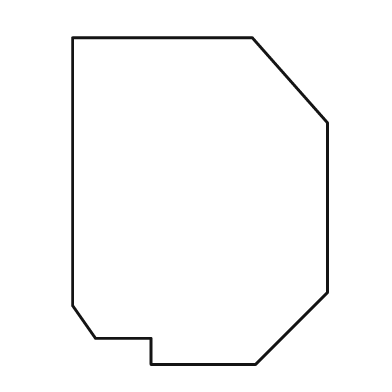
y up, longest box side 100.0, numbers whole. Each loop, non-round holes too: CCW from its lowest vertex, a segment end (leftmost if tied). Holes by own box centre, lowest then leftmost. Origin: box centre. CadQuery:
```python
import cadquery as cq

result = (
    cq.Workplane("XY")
    .moveTo(-15.0, -50.0)
    .lineTo(17.0, -50.0)
    .lineTo(39.0, -28.0)
    .lineTo(39.0, 24.0)
    .lineTo(16.0, 50.0)
    .lineTo(-39.0, 50.0)
    .lineTo(-39.0, -32.0)
    .lineTo(-32.0, -42.0)
    .lineTo(-15.0, -42.0)
    .close()
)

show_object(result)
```